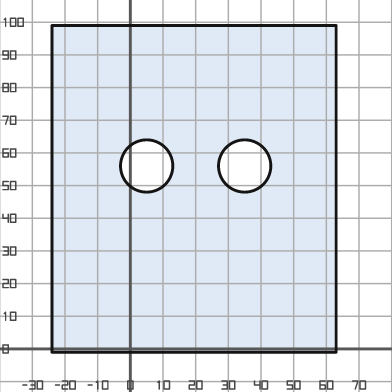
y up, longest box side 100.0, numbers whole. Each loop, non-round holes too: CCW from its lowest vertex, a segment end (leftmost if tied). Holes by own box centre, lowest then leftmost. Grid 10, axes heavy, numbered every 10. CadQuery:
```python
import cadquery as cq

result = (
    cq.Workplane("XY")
    .moveTo(-24.0, -1.0)
    .lineTo(63.0, -1.0)
    .lineTo(63.0, 99.0)
    .lineTo(-24.0, 99.0)
    .close()
    .moveTo(5.0, 56.0)
    .circle(8.0)
    .moveTo(35.0, 56.0)
    .circle(8.0)
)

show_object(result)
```